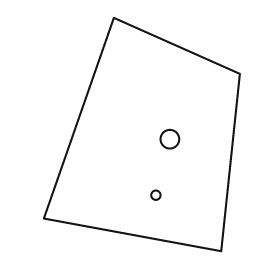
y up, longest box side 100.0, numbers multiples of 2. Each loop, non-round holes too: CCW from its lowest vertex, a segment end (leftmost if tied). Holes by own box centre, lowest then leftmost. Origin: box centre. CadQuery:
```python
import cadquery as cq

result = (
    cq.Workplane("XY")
    .moveTo(34.0, -50.0)
    .lineTo(42.0, 26.0)
    .lineTo(-12.0, 50.0)
    .lineTo(-42.0, -36.0)
    .close()
    .moveTo(6.0, -26.0)
    .circle(2.0)
    .moveTo(12.0, -2.0)
    .circle(4.0)
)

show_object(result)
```